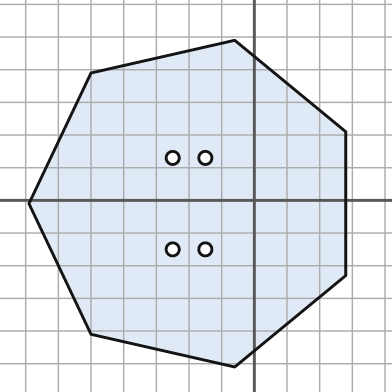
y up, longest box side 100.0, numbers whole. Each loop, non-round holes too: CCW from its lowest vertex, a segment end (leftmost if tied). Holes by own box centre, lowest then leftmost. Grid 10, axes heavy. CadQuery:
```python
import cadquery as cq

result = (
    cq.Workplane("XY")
    .moveTo(-6.0, -51.0)
    .lineTo(28.0, -23.0)
    .lineTo(28.0, 21.0)
    .lineTo(-6.0, 49.0)
    .lineTo(-50.0, 39.0)
    .lineTo(-69.0, -1.0)
    .lineTo(-50.0, -41.0)
    .close()
    .moveTo(-25.0, -15.0)
    .circle(2.0)
    .moveTo(-15.0, -15.0)
    .circle(2.0)
    .moveTo(-25.0, 13.0)
    .circle(2.0)
    .moveTo(-15.0, 13.0)
    .circle(2.0)
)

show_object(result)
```